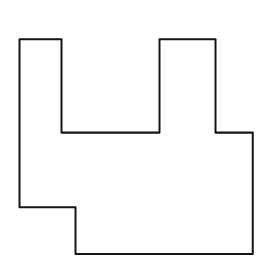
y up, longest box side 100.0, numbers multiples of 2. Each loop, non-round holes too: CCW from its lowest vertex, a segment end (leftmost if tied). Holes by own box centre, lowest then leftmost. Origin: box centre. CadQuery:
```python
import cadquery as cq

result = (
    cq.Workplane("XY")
    .moveTo(-26.0, -46.0)
    .lineTo(50.0, -46.0)
    .lineTo(50.0, 6.0)
    .lineTo(34.0, 6.0)
    .lineTo(34.0, 46.0)
    .lineTo(10.0, 46.0)
    .lineTo(10.0, 6.0)
    .lineTo(-32.0, 6.0)
    .lineTo(-32.0, 46.0)
    .lineTo(-50.0, 46.0)
    .lineTo(-50.0, -26.0)
    .lineTo(-26.0, -26.0)
    .close()
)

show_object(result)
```